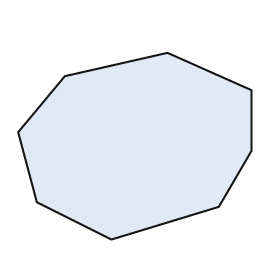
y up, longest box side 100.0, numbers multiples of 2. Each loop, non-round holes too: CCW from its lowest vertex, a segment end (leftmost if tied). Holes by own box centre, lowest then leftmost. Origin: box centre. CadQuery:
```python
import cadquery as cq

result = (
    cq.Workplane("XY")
    .moveTo(-10.0, -40.0)
    .lineTo(36.0, -26.0)
    .lineTo(50.0, -2.0)
    .lineTo(50.0, 24.0)
    .lineTo(14.0, 40.0)
    .lineTo(-30.0, 30.0)
    .lineTo(-50.0, 6.0)
    .lineTo(-42.0, -24.0)
    .close()
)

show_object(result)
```